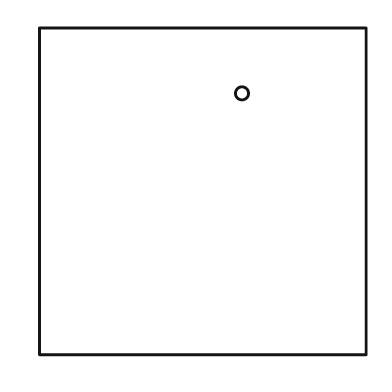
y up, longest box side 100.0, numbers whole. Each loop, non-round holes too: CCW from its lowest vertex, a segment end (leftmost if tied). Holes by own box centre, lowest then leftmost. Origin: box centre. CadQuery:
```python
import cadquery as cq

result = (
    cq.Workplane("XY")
    .moveTo(-50.0, -50.0)
    .lineTo(50.0, -50.0)
    .lineTo(50.0, 50.0)
    .lineTo(-50.0, 50.0)
    .close()
    .moveTo(12.0, 30.0)
    .circle(2.0)
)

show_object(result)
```